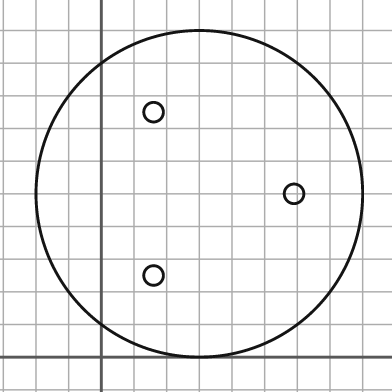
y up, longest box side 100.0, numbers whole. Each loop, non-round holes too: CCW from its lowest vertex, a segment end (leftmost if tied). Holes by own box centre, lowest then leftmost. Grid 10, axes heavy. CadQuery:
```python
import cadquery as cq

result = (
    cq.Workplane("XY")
    .moveTo(30.0, 50.0)
    .circle(50.0)
    .moveTo(16.0, 25.0)
    .circle(3.0)
    .moveTo(59.0, 50.0)
    .circle(3.0)
    .moveTo(16.0, 75.0)
    .circle(3.0)
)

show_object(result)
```